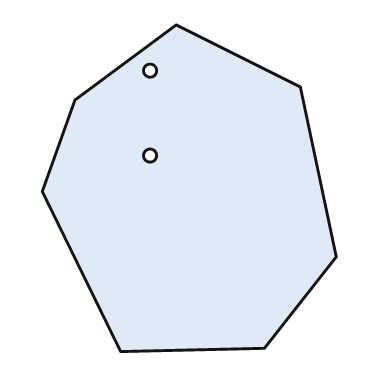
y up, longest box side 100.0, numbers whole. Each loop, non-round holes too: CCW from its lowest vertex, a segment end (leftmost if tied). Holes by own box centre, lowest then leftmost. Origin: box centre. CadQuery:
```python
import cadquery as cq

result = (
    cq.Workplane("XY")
    .moveTo(-21.0, -50.0)
    .lineTo(23.0, -49.0)
    .lineTo(45.0, -21.0)
    .lineTo(34.0, 31.0)
    .lineTo(-4.0, 50.0)
    .lineTo(-35.0, 27.0)
    .lineTo(-45.0, -1.0)
    .close()
    .moveTo(-12.0, 10.0)
    .circle(2.0)
    .moveTo(-12.0, 36.0)
    .circle(2.0)
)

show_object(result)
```